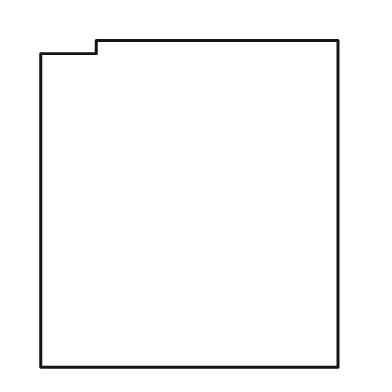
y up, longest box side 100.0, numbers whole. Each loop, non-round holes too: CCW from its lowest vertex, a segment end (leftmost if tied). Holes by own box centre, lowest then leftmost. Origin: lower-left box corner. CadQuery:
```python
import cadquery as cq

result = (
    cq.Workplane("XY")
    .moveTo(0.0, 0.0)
    .lineTo(91.0, 0.0)
    .lineTo(91.0, 100.0)
    .lineTo(17.0, 100.0)
    .lineTo(17.0, 96.0)
    .lineTo(0.0, 96.0)
    .close()
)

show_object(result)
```